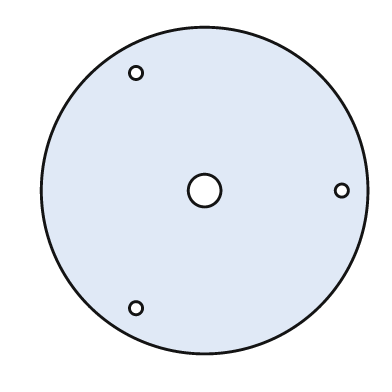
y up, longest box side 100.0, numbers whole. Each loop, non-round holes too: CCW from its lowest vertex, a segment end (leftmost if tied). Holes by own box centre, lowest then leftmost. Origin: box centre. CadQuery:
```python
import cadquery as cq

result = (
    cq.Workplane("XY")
    .moveTo(0.0, 0.0)
    .circle(50.0)
    .moveTo(-21.0, -36.0)
    .circle(2.0)
    .moveTo(0.0, 0.0)
    .circle(5.0)
    .moveTo(42.0, 0.0)
    .circle(2.0)
    .moveTo(-21.0, 36.0)
    .circle(2.0)
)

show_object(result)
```